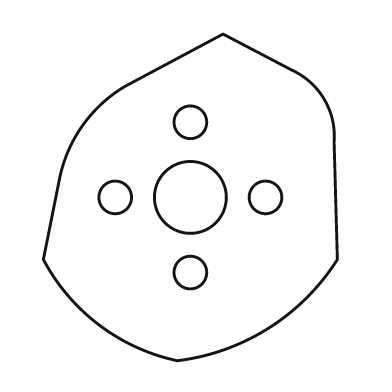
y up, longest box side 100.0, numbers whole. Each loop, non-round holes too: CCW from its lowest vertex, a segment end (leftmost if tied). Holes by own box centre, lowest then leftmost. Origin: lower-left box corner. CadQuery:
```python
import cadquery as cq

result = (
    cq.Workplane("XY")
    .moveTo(41.0, 0.0)
    .threePointArc((69.0, 10.0), (90.0, 31.0))
    .lineTo(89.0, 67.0)
    .threePointArc((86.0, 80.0), (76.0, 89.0))
    .lineTo(55.0, 100.0)
    .lineTo(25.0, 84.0)
    .threePointArc((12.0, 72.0), (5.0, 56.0))
    .lineTo(0.0, 31.0)
    .threePointArc((17.0, 11.0), (41.0, 0.0))
    .close()
    .moveTo(45.0, 27.0)
    .circle(5.0)
    .moveTo(22.0, 50.0)
    .circle(5.0)
    .moveTo(45.0, 50.0)
    .circle(11.0)
    .moveTo(68.0, 50.0)
    .circle(5.0)
    .moveTo(45.0, 73.0)
    .circle(5.0)
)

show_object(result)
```